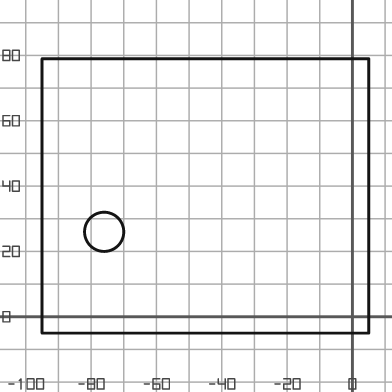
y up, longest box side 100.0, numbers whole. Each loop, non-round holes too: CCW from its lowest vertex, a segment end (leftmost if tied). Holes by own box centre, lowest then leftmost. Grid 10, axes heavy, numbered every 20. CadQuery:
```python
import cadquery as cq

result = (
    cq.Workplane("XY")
    .moveTo(-95.0, -5.0)
    .lineTo(5.0, -5.0)
    .lineTo(5.0, 79.0)
    .lineTo(-95.0, 79.0)
    .close()
    .moveTo(-76.0, 26.0)
    .circle(6.0)
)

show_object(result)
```